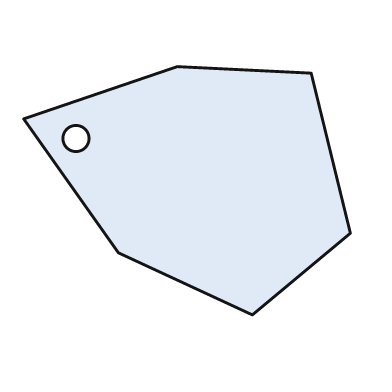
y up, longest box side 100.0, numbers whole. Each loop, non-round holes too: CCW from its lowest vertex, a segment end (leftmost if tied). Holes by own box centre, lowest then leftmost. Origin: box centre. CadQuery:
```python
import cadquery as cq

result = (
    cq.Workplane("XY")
    .moveTo(20.0, -38.0)
    .lineTo(50.0, -13.0)
    .lineTo(38.0, 36.0)
    .lineTo(-3.0, 38.0)
    .lineTo(-50.0, 22.0)
    .lineTo(-21.0, -19.0)
    .close()
    .moveTo(-34.0, 16.0)
    .circle(4.0)
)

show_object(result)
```